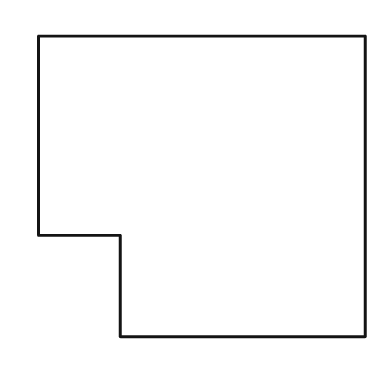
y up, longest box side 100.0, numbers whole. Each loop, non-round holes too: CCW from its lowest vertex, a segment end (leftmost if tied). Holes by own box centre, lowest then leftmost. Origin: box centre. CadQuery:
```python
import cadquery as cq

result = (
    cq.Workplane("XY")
    .moveTo(-25.0, -46.0)
    .lineTo(50.0, -46.0)
    .lineTo(50.0, 46.0)
    .lineTo(-50.0, 46.0)
    .lineTo(-50.0, -15.0)
    .lineTo(-25.0, -15.0)
    .close()
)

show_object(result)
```